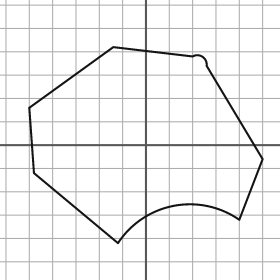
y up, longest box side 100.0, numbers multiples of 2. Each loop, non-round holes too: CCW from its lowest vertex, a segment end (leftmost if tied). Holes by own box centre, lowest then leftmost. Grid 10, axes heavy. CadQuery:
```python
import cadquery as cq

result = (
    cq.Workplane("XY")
    .moveTo(-12.0, -42.0)
    .threePointArc((12.0, -26.0), (40.0, -32.0))
    .lineTo(50.0, -6.0)
    .lineTo(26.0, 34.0)
    .threePointArc((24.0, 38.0), (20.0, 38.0))
    .lineTo(-14.0, 42.0)
    .lineTo(-50.0, 16.0)
    .lineTo(-48.0, -12.0)
    .close()
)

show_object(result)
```